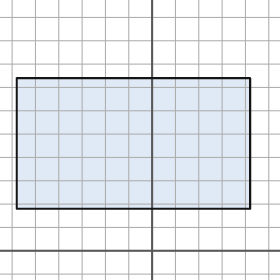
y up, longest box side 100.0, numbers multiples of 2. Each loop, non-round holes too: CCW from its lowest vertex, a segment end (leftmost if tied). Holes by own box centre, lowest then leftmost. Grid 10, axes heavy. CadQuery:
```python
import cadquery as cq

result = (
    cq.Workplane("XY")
    .moveTo(-58.0, 18.0)
    .lineTo(42.0, 18.0)
    .lineTo(42.0, 74.0)
    .lineTo(-58.0, 74.0)
    .close()
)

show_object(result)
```